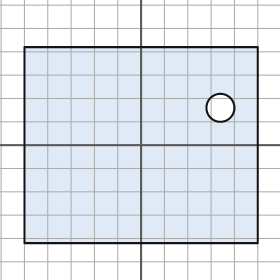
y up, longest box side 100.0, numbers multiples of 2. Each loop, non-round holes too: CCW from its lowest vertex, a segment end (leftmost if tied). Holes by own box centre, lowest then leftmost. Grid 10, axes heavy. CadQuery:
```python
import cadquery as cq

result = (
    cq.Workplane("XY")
    .moveTo(-50.0, -42.0)
    .lineTo(50.0, -42.0)
    .lineTo(50.0, 42.0)
    .lineTo(-50.0, 42.0)
    .close()
    .moveTo(34.0, 16.0)
    .circle(6.0)
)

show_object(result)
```